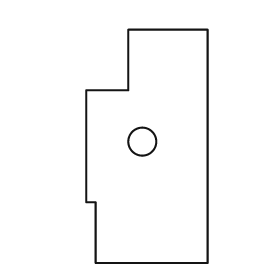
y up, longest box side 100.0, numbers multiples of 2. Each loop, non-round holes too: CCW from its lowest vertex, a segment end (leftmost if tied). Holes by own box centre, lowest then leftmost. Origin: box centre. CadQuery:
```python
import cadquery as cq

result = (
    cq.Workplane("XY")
    .moveTo(-22.0, -50.0)
    .lineTo(26.0, -50.0)
    .lineTo(26.0, 50.0)
    .lineTo(-8.0, 50.0)
    .lineTo(-8.0, 24.0)
    .lineTo(-26.0, 24.0)
    .lineTo(-26.0, -24.0)
    .lineTo(-22.0, -24.0)
    .close()
    .moveTo(-2.0, 2.0)
    .circle(6.0)
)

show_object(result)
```